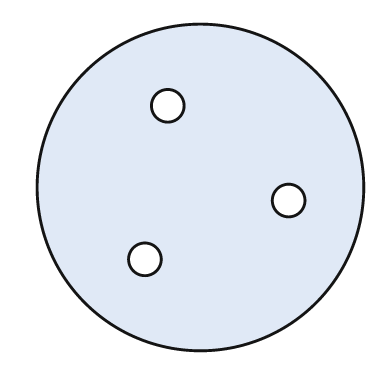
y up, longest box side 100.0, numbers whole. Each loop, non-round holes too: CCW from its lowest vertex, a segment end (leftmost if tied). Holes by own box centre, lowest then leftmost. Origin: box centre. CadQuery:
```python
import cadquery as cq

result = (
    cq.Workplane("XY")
    .moveTo(0.0, 0.0)
    .circle(50.0)
    .moveTo(-17.0, -22.0)
    .circle(5.0)
    .moveTo(27.0, -4.0)
    .circle(5.0)
    .moveTo(-10.0, 25.0)
    .circle(5.0)
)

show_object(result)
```